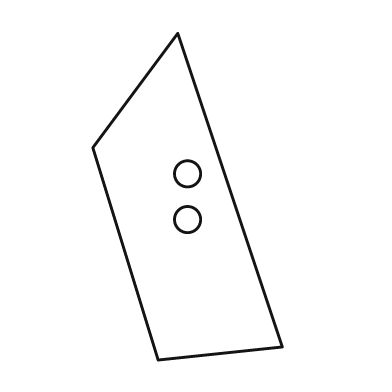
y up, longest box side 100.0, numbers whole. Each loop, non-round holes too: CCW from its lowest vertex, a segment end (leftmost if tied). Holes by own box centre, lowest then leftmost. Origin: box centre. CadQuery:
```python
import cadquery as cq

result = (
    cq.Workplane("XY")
    .moveTo(-9.0, -50.0)
    .lineTo(29.0, -46.0)
    .lineTo(-3.0, 50.0)
    .lineTo(-29.0, 15.0)
    .close()
    .moveTo(0.0, -7.0)
    .circle(4.0)
    .moveTo(0.0, 7.0)
    .circle(4.0)
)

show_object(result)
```